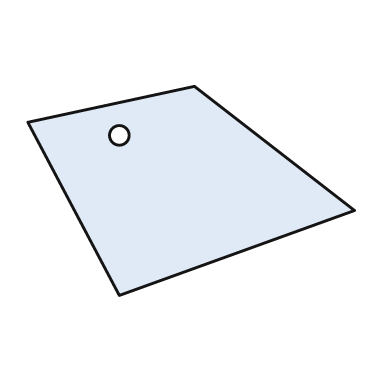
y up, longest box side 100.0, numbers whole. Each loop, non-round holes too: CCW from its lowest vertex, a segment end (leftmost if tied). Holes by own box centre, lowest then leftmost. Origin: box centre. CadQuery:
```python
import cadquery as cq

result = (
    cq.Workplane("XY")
    .moveTo(-22.0, -32.0)
    .lineTo(50.0, -6.0)
    .lineTo(1.0, 32.0)
    .lineTo(-50.0, 21.0)
    .close()
    .moveTo(-22.0, 17.0)
    .circle(3.0)
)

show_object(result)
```